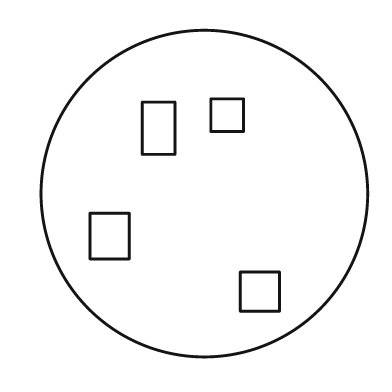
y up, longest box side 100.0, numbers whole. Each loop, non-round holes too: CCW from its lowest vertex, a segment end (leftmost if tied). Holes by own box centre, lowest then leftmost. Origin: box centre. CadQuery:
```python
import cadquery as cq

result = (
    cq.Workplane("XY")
    .moveTo(0.0, 0.0)
    .circle(50.0)
    .moveTo(11.0, -36.0)
    .lineTo(23.0, -36.0)
    .lineTo(23.0, -24.0)
    .lineTo(11.0, -24.0)
    .close()
    .moveTo(-35.0, -20.0)
    .lineTo(-23.0, -20.0)
    .lineTo(-23.0, -6.0)
    .lineTo(-35.0, -6.0)
    .close()
    .moveTo(-19.0, 12.0)
    .lineTo(-9.0, 12.0)
    .lineTo(-9.0, 28.0)
    .lineTo(-19.0, 28.0)
    .close()
    .moveTo(2.0, 19.0)
    .lineTo(12.0, 19.0)
    .lineTo(12.0, 29.0)
    .lineTo(2.0, 29.0)
    .close()
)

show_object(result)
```